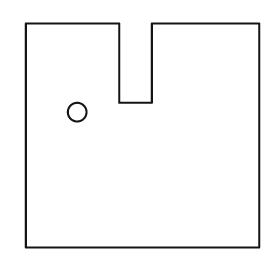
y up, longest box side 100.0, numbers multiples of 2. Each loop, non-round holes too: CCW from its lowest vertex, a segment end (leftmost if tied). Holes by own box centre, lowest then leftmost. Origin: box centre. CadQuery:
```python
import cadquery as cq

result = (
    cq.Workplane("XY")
    .moveTo(-50.0, -48.0)
    .lineTo(50.0, -48.0)
    .lineTo(50.0, 48.0)
    .lineTo(4.0, 48.0)
    .lineTo(4.0, 14.0)
    .lineTo(-10.0, 14.0)
    .lineTo(-10.0, 48.0)
    .lineTo(-50.0, 48.0)
    .close()
    .moveTo(-28.0, 10.0)
    .circle(4.0)
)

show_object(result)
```